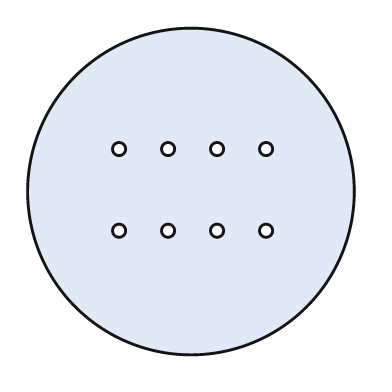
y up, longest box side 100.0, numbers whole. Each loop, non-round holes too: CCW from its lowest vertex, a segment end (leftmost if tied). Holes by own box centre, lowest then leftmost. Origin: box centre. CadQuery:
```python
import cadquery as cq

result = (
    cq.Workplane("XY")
    .moveTo(0.0, 0.0)
    .circle(50.0)
    .moveTo(-22.0, -12.0)
    .circle(2.0)
    .moveTo(-7.0, -12.0)
    .circle(2.0)
    .moveTo(8.0, -12.0)
    .circle(2.0)
    .moveTo(23.0, -12.0)
    .circle(2.0)
    .moveTo(-22.0, 13.0)
    .circle(2.0)
    .moveTo(-7.0, 13.0)
    .circle(2.0)
    .moveTo(8.0, 13.0)
    .circle(2.0)
    .moveTo(23.0, 13.0)
    .circle(2.0)
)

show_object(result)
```